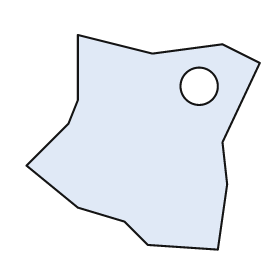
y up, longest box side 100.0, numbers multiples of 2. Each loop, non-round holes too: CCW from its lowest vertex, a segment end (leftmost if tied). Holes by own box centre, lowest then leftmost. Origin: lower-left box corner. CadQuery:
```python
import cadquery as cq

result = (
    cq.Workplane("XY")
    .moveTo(82.0, 0.0)
    .lineTo(86.0, 28.0)
    .lineTo(84.0, 46.0)
    .lineTo(100.0, 80.0)
    .lineTo(84.0, 88.0)
    .lineTo(54.0, 84.0)
    .lineTo(22.0, 92.0)
    .lineTo(22.0, 64.0)
    .lineTo(18.0, 54.0)
    .lineTo(0.0, 36.0)
    .lineTo(22.0, 18.0)
    .lineTo(42.0, 12.0)
    .lineTo(52.0, 2.0)
    .close()
    .moveTo(74.0, 70.0)
    .circle(8.0)
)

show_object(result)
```